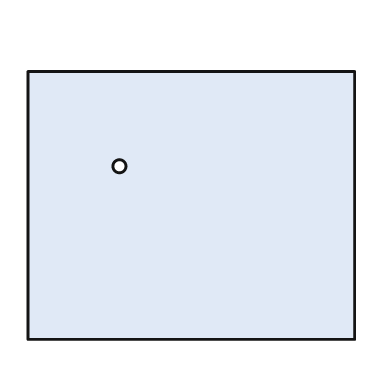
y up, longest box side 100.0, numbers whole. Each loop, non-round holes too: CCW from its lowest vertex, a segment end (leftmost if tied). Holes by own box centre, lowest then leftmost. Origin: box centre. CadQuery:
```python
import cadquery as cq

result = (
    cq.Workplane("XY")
    .moveTo(-50.0, -41.0)
    .lineTo(50.0, -41.0)
    .lineTo(50.0, 41.0)
    .lineTo(-50.0, 41.0)
    .close()
    .moveTo(-22.0, 12.0)
    .circle(2.0)
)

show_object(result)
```